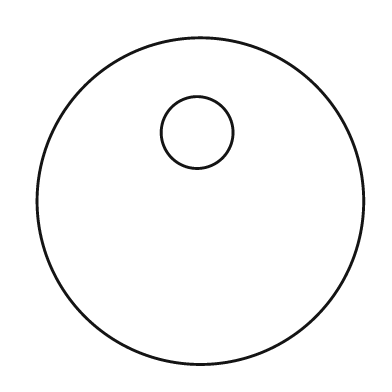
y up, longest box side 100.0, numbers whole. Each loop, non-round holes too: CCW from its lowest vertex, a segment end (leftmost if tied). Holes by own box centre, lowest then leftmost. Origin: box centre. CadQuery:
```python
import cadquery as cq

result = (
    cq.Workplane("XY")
    .moveTo(0.0, 0.0)
    .circle(50.0)
    .moveTo(-1.0, 21.0)
    .circle(11.0)
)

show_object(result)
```